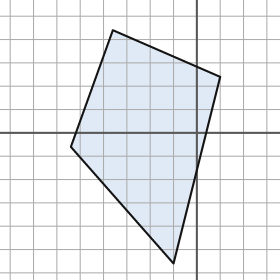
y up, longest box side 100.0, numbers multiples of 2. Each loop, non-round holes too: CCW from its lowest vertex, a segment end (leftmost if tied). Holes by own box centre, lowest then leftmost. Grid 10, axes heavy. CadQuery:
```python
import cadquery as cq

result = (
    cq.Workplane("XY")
    .moveTo(-10.0, -56.0)
    .lineTo(10.0, 24.0)
    .lineTo(-36.0, 44.0)
    .lineTo(-54.0, -6.0)
    .close()
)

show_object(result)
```